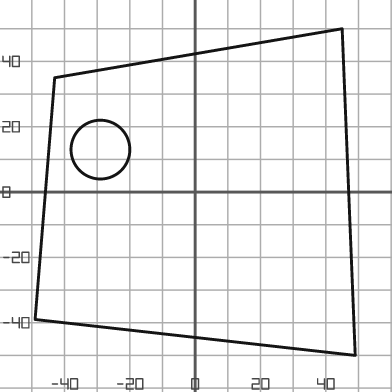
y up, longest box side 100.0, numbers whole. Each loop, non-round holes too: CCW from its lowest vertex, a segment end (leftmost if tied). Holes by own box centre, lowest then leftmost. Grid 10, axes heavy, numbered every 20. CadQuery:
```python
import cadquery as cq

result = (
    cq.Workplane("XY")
    .moveTo(49.0, -50.0)
    .lineTo(45.0, 50.0)
    .lineTo(-43.0, 35.0)
    .lineTo(-49.0, -39.0)
    .close()
    .moveTo(-29.0, 13.0)
    .circle(9.0)
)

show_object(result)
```